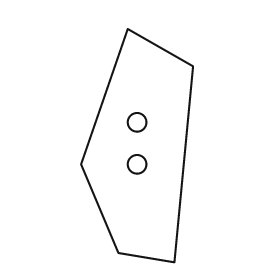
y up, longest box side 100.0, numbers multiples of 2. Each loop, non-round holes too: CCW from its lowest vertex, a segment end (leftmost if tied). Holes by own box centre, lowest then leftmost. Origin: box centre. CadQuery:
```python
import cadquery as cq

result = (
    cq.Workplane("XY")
    .moveTo(16.0, -50.0)
    .lineTo(24.0, 34.0)
    .lineTo(-4.0, 50.0)
    .lineTo(-24.0, -8.0)
    .lineTo(-8.0, -46.0)
    .close()
    .moveTo(0.0, -8.0)
    .circle(4.0)
    .moveTo(0.0, 10.0)
    .circle(4.0)
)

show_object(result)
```